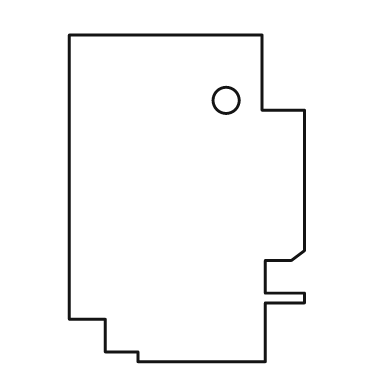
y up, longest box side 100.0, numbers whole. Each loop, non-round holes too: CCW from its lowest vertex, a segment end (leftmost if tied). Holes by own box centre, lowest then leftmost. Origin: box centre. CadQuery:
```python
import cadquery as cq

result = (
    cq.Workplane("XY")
    .moveTo(-15.0, -50.0)
    .lineTo(24.0, -50.0)
    .lineTo(24.0, -32.0)
    .lineTo(36.0, -32.0)
    .lineTo(36.0, -29.0)
    .lineTo(24.0, -29.0)
    .lineTo(24.0, -19.0)
    .lineTo(32.0, -19.0)
    .lineTo(36.0, -16.0)
    .lineTo(36.0, 27.0)
    .lineTo(23.0, 27.0)
    .lineTo(23.0, 50.0)
    .lineTo(-36.0, 50.0)
    .lineTo(-36.0, -37.0)
    .lineTo(-25.0, -37.0)
    .lineTo(-25.0, -47.0)
    .lineTo(-15.0, -47.0)
    .close()
    .moveTo(12.0, 30.0)
    .circle(4.0)
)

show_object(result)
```